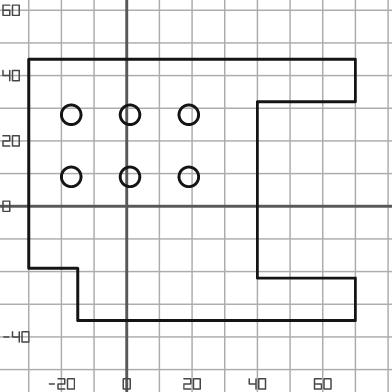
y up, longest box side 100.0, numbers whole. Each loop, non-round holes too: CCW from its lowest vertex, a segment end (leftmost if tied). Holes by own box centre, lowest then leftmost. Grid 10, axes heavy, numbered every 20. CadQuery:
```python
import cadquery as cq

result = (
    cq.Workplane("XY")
    .moveTo(-15.0, -35.0)
    .lineTo(70.0, -35.0)
    .lineTo(70.0, -22.0)
    .lineTo(40.0, -22.0)
    .lineTo(40.0, 32.0)
    .lineTo(70.0, 32.0)
    .lineTo(70.0, 45.0)
    .lineTo(-30.0, 45.0)
    .lineTo(-30.0, -19.0)
    .lineTo(-15.0, -19.0)
    .close()
    .moveTo(-17.0, 9.0)
    .circle(3.0)
    .moveTo(1.0, 9.0)
    .circle(3.0)
    .moveTo(19.0, 9.0)
    .circle(3.0)
    .moveTo(-17.0, 28.0)
    .circle(3.0)
    .moveTo(1.0, 28.0)
    .circle(3.0)
    .moveTo(19.0, 28.0)
    .circle(3.0)
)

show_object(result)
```